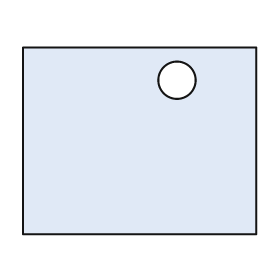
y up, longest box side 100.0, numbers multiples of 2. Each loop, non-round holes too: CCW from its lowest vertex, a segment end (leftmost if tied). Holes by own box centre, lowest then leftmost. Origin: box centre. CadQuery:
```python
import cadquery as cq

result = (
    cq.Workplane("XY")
    .moveTo(-50.0, -40.0)
    .lineTo(50.0, -40.0)
    .lineTo(50.0, 40.0)
    .lineTo(-50.0, 40.0)
    .close()
    .moveTo(16.0, 26.0)
    .circle(8.0)
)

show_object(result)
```